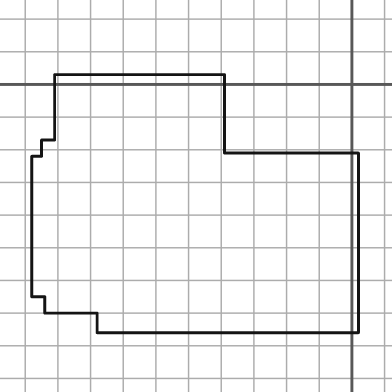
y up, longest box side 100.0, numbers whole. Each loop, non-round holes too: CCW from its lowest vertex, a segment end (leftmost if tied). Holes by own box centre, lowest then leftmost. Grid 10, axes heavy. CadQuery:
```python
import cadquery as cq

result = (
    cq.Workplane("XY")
    .moveTo(-78.0, -76.0)
    .lineTo(2.0, -76.0)
    .lineTo(2.0, -21.0)
    .lineTo(-39.0, -21.0)
    .lineTo(-39.0, 3.0)
    .lineTo(-91.0, 3.0)
    .lineTo(-91.0, -17.0)
    .lineTo(-95.0, -17.0)
    .lineTo(-95.0, -22.0)
    .lineTo(-98.0, -22.0)
    .lineTo(-98.0, -65.0)
    .lineTo(-94.0, -65.0)
    .lineTo(-94.0, -70.0)
    .lineTo(-78.0, -70.0)
    .close()
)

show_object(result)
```